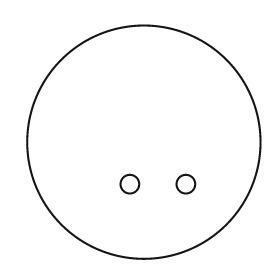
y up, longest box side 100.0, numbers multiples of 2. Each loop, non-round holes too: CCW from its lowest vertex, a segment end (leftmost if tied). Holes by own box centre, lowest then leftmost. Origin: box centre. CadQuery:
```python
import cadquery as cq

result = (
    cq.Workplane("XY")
    .moveTo(0.0, 0.0)
    .circle(50.0)
    .moveTo(-6.0, -18.0)
    .circle(4.0)
    .moveTo(18.0, -18.0)
    .circle(4.0)
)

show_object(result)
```